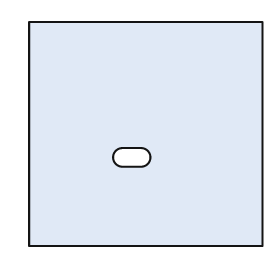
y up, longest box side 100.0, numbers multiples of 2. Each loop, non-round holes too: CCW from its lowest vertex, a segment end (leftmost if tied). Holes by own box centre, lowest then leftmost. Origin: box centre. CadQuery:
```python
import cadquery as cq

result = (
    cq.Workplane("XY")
    .moveTo(-50.0, -48.0)
    .lineTo(50.0, -48.0)
    .lineTo(50.0, 48.0)
    .lineTo(-50.0, 48.0)
    .close()
    .moveTo(-10.0, -14.0)
    .lineTo(-2.0, -14.0)
    .threePointArc((2.0, -10.0), (-2.0, -6.0))
    .lineTo(-10.0, -6.0)
    .threePointArc((-14.0, -10.0), (-10.0, -14.0))
    .close()
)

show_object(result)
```